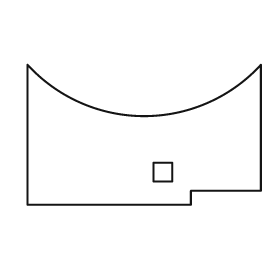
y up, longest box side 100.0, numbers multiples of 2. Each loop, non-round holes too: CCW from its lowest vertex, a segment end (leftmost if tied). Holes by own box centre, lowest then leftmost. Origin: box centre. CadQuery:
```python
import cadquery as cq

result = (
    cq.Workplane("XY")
    .moveTo(-50.0, -30.0)
    .lineTo(20.0, -30.0)
    .lineTo(20.0, -24.0)
    .lineTo(50.0, -24.0)
    .lineTo(50.0, 30.0)
    .threePointArc((0.0, 8.0), (-50.0, 30.0))
    .close()
    .moveTo(4.0, -20.0)
    .lineTo(12.0, -20.0)
    .lineTo(12.0, -12.0)
    .lineTo(4.0, -12.0)
    .close()
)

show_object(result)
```